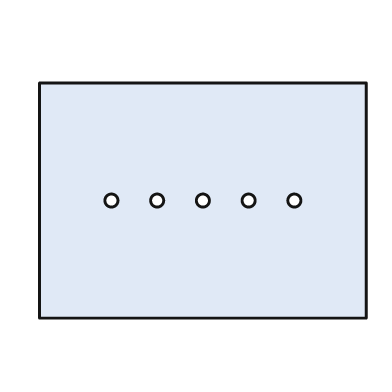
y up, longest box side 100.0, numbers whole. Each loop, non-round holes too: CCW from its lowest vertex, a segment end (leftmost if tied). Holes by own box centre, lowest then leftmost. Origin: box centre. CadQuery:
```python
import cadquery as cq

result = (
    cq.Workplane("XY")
    .moveTo(-50.0, -36.0)
    .lineTo(50.0, -36.0)
    .lineTo(50.0, 36.0)
    .lineTo(-50.0, 36.0)
    .close()
    .moveTo(-28.0, 0.0)
    .circle(2.0)
    .moveTo(-14.0, 0.0)
    .circle(2.0)
    .moveTo(0.0, 0.0)
    .circle(2.0)
    .moveTo(14.0, 0.0)
    .circle(2.0)
    .moveTo(28.0, 0.0)
    .circle(2.0)
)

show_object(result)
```